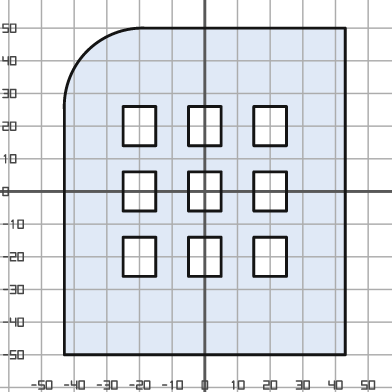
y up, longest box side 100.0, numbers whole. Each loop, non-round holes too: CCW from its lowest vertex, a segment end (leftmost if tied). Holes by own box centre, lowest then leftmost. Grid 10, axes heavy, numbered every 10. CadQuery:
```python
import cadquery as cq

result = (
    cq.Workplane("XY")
    .moveTo(-43.0, -50.0)
    .lineTo(43.0, -50.0)
    .lineTo(43.0, 50.0)
    .lineTo(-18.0, 50.0)
    .threePointArc((-36.0, 43.0), (-43.0, 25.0))
    .close()
    .moveTo(-25.0, -26.0)
    .lineTo(-15.0, -26.0)
    .lineTo(-15.0, -14.0)
    .lineTo(-25.0, -14.0)
    .close()
    .moveTo(-5.0, -26.0)
    .lineTo(5.0, -26.0)
    .lineTo(5.0, -14.0)
    .lineTo(-5.0, -14.0)
    .close()
    .moveTo(15.0, -26.0)
    .lineTo(25.0, -26.0)
    .lineTo(25.0, -14.0)
    .lineTo(15.0, -14.0)
    .close()
    .moveTo(-25.0, -6.0)
    .lineTo(-15.0, -6.0)
    .lineTo(-15.0, 6.0)
    .lineTo(-25.0, 6.0)
    .close()
    .moveTo(-5.0, -6.0)
    .lineTo(5.0, -6.0)
    .lineTo(5.0, 6.0)
    .lineTo(-5.0, 6.0)
    .close()
    .moveTo(15.0, -6.0)
    .lineTo(25.0, -6.0)
    .lineTo(25.0, 6.0)
    .lineTo(15.0, 6.0)
    .close()
    .moveTo(-25.0, 14.0)
    .lineTo(-15.0, 14.0)
    .lineTo(-15.0, 26.0)
    .lineTo(-25.0, 26.0)
    .close()
    .moveTo(-5.0, 14.0)
    .lineTo(5.0, 14.0)
    .lineTo(5.0, 26.0)
    .lineTo(-5.0, 26.0)
    .close()
    .moveTo(15.0, 14.0)
    .lineTo(25.0, 14.0)
    .lineTo(25.0, 26.0)
    .lineTo(15.0, 26.0)
    .close()
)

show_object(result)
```